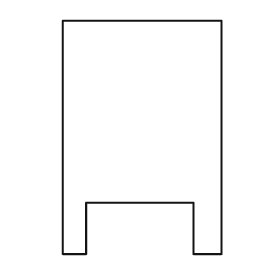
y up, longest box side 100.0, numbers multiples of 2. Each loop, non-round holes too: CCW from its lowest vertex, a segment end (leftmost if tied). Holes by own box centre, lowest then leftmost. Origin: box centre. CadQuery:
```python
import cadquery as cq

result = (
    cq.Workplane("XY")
    .moveTo(-34.0, -50.0)
    .lineTo(-24.0, -50.0)
    .lineTo(-24.0, -28.0)
    .lineTo(22.0, -28.0)
    .lineTo(22.0, -50.0)
    .lineTo(34.0, -50.0)
    .lineTo(34.0, 50.0)
    .lineTo(-34.0, 50.0)
    .close()
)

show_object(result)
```